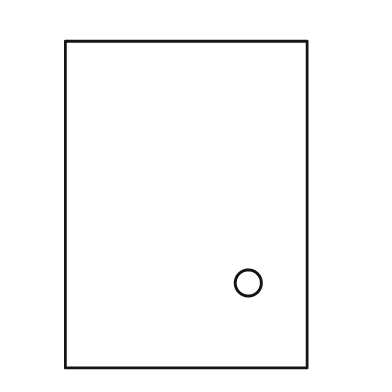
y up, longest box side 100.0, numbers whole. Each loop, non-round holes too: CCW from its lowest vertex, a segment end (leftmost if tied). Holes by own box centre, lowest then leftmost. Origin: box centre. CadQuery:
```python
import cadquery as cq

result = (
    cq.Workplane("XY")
    .moveTo(-37.0, -50.0)
    .lineTo(37.0, -50.0)
    .lineTo(37.0, 50.0)
    .lineTo(-37.0, 50.0)
    .close()
    .moveTo(19.0, -24.0)
    .circle(4.0)
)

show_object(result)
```